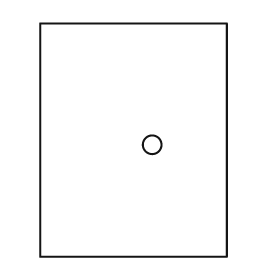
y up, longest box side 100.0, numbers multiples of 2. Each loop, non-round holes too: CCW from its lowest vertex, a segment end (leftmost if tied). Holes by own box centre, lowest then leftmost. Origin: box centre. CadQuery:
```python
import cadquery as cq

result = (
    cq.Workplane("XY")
    .moveTo(-40.0, -50.0)
    .lineTo(40.0, -50.0)
    .lineTo(40.0, 50.0)
    .lineTo(-40.0, 50.0)
    .close()
    .moveTo(8.0, -2.0)
    .circle(4.0)
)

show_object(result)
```